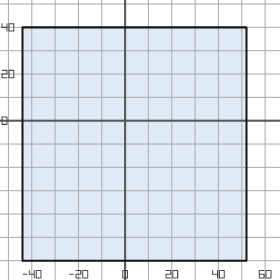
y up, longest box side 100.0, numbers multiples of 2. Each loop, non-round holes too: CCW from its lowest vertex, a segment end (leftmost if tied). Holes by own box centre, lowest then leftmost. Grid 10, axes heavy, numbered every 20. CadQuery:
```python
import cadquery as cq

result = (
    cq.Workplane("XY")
    .moveTo(-44.0, -60.0)
    .lineTo(52.0, -60.0)
    .lineTo(52.0, 40.0)
    .lineTo(-44.0, 40.0)
    .close()
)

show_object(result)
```